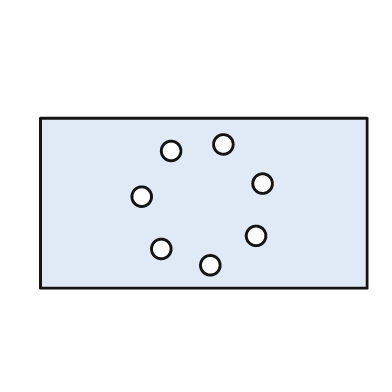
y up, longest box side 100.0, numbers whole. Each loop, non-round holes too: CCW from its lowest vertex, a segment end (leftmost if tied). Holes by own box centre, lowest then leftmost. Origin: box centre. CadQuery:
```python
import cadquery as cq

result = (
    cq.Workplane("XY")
    .moveTo(-50.0, -26.0)
    .lineTo(50.0, -26.0)
    .lineTo(50.0, 26.0)
    .lineTo(-50.0, 26.0)
    .close()
    .moveTo(2.0, -19.0)
    .circle(3.0)
    .moveTo(-13.0, -14.0)
    .circle(3.0)
    .moveTo(16.0, -10.0)
    .circle(3.0)
    .moveTo(-19.0, 2.0)
    .circle(3.0)
    .moveTo(18.0, 6.0)
    .circle(3.0)
    .moveTo(-10.0, 16.0)
    .circle(3.0)
    .moveTo(6.0, 18.0)
    .circle(3.0)
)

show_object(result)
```